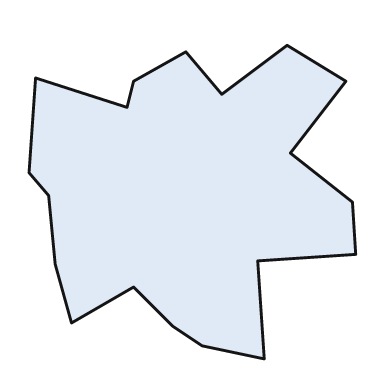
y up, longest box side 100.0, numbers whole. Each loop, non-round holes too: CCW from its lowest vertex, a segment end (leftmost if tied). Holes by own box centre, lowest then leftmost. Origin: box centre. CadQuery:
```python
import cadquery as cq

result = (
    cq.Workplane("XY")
    .moveTo(22.0, -48.0)
    .lineTo(20.0, -18.0)
    .lineTo(50.0, -16.0)
    .lineTo(49.0, 0.0)
    .lineTo(30.0, 15.0)
    .lineTo(47.0, 37.0)
    .lineTo(29.0, 48.0)
    .lineTo(9.0, 33.0)
    .lineTo(-2.0, 46.0)
    .lineTo(-18.0, 37.0)
    .lineTo(-20.0, 29.0)
    .lineTo(-48.0, 38.0)
    .lineTo(-50.0, 9.0)
    .lineTo(-44.0, 2.0)
    .lineTo(-42.0, -19.0)
    .lineTo(-37.0, -37.0)
    .lineTo(-18.0, -26.0)
    .lineTo(-6.0, -38.0)
    .lineTo(3.0, -44.0)
    .close()
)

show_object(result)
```